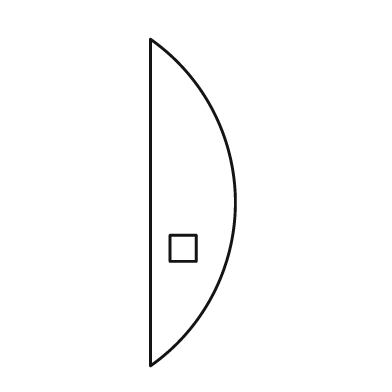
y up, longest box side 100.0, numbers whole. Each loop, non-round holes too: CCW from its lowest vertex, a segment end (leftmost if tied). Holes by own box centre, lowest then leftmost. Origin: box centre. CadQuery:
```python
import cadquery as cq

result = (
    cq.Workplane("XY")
    .moveTo(-13.0, -50.0)
    .threePointArc((13.0, 0.0), (-13.0, 50.0))
    .close()
    .moveTo(-7.0, -18.0)
    .lineTo(1.0, -18.0)
    .lineTo(1.0, -10.0)
    .lineTo(-7.0, -10.0)
    .close()
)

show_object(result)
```